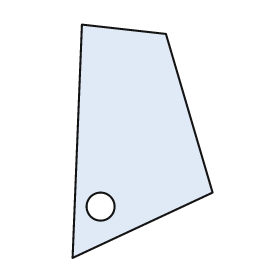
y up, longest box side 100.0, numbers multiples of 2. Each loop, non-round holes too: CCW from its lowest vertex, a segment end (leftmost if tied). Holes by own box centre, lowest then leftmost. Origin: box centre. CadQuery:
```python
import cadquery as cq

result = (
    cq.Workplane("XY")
    .moveTo(-30.0, -50.0)
    .lineTo(30.0, -22.0)
    .lineTo(10.0, 46.0)
    .lineTo(-26.0, 50.0)
    .close()
    .moveTo(-18.0, -28.0)
    .circle(6.0)
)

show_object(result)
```